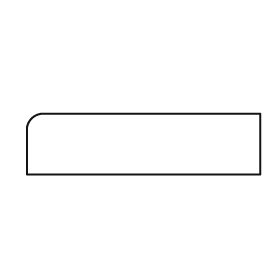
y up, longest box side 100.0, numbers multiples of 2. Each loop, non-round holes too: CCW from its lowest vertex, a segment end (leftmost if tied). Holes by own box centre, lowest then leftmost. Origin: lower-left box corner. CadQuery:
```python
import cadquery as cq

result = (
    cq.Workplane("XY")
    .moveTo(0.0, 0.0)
    .lineTo(100.0, 0.0)
    .lineTo(100.0, 26.0)
    .lineTo(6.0, 26.0)
    .threePointArc((2.0, 24.0), (0.0, 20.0))
    .close()
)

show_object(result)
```